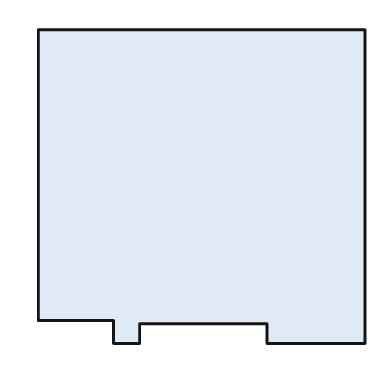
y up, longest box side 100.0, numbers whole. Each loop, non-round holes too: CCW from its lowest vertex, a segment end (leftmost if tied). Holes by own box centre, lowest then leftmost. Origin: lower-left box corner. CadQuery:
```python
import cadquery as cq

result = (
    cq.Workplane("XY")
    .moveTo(23.0, 0.0)
    .lineTo(31.0, 0.0)
    .lineTo(31.0, 6.0)
    .lineTo(70.0, 6.0)
    .lineTo(70.0, 0.0)
    .lineTo(100.0, 0.0)
    .lineTo(100.0, 96.0)
    .lineTo(0.0, 96.0)
    .lineTo(0.0, 7.0)
    .lineTo(23.0, 7.0)
    .close()
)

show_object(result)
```